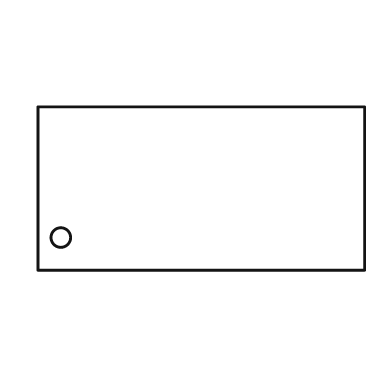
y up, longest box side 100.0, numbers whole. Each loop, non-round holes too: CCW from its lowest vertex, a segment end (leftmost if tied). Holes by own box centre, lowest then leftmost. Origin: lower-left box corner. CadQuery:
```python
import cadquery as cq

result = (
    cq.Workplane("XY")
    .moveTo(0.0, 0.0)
    .lineTo(100.0, 0.0)
    .lineTo(100.0, 50.0)
    .lineTo(0.0, 50.0)
    .close()
    .moveTo(7.0, 10.0)
    .circle(3.0)
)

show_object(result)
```